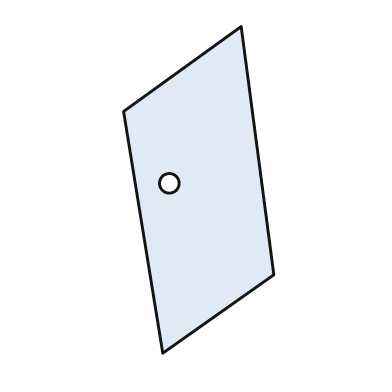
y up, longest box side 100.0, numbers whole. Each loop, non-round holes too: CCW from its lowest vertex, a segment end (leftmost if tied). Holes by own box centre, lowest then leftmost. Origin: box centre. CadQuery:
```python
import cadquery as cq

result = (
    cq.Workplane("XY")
    .moveTo(-11.0, -50.0)
    .lineTo(23.0, -26.0)
    .lineTo(13.0, 50.0)
    .lineTo(-23.0, 24.0)
    .close()
    .moveTo(-9.0, 2.0)
    .circle(3.0)
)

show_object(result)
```